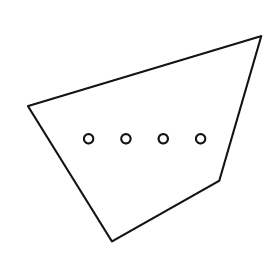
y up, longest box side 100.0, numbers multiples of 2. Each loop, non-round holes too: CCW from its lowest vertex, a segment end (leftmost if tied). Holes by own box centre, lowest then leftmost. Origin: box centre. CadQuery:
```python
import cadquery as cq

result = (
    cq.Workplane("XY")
    .moveTo(-14.0, -44.0)
    .lineTo(32.0, -18.0)
    .lineTo(50.0, 44.0)
    .lineTo(-50.0, 14.0)
    .close()
    .moveTo(-24.0, 0.0)
    .circle(2.0)
    .moveTo(-8.0, 0.0)
    .circle(2.0)
    .moveTo(8.0, 0.0)
    .circle(2.0)
    .moveTo(24.0, 0.0)
    .circle(2.0)
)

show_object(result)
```